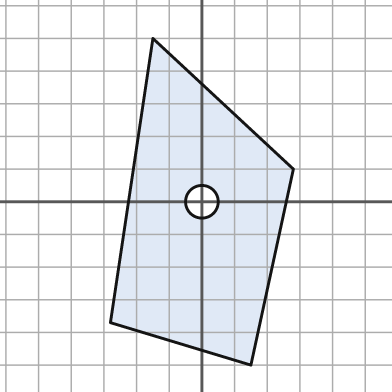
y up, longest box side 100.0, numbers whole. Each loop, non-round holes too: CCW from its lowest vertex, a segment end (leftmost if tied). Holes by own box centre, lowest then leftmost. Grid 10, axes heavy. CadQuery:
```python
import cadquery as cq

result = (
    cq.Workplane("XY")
    .moveTo(15.0, -50.0)
    .lineTo(28.0, 10.0)
    .lineTo(-15.0, 50.0)
    .lineTo(-28.0, -37.0)
    .close()
    .moveTo(0.0, 0.0)
    .circle(5.0)
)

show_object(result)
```